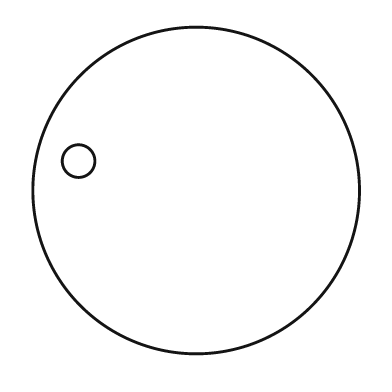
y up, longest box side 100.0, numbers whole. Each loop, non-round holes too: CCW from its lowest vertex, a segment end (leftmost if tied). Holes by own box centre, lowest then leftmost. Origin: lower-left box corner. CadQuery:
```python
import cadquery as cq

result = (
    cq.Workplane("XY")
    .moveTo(50.0, 50.0)
    .circle(50.0)
    .moveTo(14.0, 59.0)
    .circle(5.0)
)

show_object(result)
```